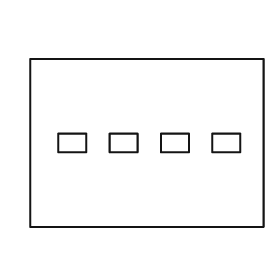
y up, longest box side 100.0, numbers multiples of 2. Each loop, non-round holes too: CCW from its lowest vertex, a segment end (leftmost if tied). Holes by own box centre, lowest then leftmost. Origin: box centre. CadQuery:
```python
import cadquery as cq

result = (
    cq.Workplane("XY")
    .moveTo(-50.0, -36.0)
    .lineTo(50.0, -36.0)
    .lineTo(50.0, 36.0)
    .lineTo(-50.0, 36.0)
    .close()
    .moveTo(-38.0, -4.0)
    .lineTo(-26.0, -4.0)
    .lineTo(-26.0, 4.0)
    .lineTo(-38.0, 4.0)
    .close()
    .moveTo(-16.0, -4.0)
    .lineTo(-4.0, -4.0)
    .lineTo(-4.0, 4.0)
    .lineTo(-16.0, 4.0)
    .close()
    .moveTo(6.0, -4.0)
    .lineTo(18.0, -4.0)
    .lineTo(18.0, 4.0)
    .lineTo(6.0, 4.0)
    .close()
    .moveTo(28.0, -4.0)
    .lineTo(40.0, -4.0)
    .lineTo(40.0, 4.0)
    .lineTo(28.0, 4.0)
    .close()
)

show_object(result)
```